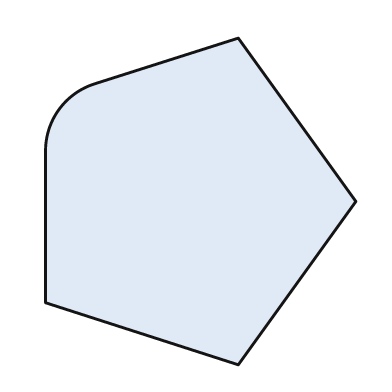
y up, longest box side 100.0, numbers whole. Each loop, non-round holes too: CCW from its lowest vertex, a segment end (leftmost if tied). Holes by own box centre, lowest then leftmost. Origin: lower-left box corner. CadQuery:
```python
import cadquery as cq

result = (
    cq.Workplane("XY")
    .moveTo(59.0, 0.0)
    .lineTo(95.0, 50.0)
    .lineTo(59.0, 100.0)
    .lineTo(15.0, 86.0)
    .threePointArc((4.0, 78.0), (0.0, 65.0))
    .lineTo(0.0, 19.0)
    .close()
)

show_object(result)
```